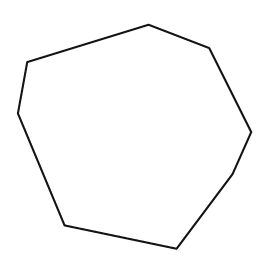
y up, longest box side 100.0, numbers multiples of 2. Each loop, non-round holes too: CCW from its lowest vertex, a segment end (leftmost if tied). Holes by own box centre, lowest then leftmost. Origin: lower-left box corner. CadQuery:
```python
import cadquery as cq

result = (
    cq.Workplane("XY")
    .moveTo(68.0, 0.0)
    .lineTo(92.0, 32.0)
    .lineTo(100.0, 50.0)
    .lineTo(82.0, 86.0)
    .lineTo(56.0, 96.0)
    .lineTo(4.0, 80.0)
    .lineTo(0.0, 58.0)
    .lineTo(20.0, 10.0)
    .close()
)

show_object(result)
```